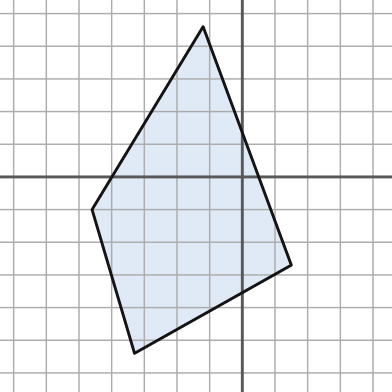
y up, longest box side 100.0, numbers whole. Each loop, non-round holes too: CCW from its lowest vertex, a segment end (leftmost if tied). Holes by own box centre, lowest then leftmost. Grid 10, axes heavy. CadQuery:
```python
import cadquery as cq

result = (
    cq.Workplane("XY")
    .moveTo(-33.0, -54.0)
    .lineTo(15.0, -27.0)
    .lineTo(-12.0, 46.0)
    .lineTo(-46.0, -10.0)
    .close()
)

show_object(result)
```